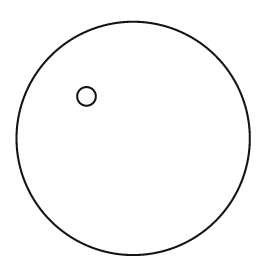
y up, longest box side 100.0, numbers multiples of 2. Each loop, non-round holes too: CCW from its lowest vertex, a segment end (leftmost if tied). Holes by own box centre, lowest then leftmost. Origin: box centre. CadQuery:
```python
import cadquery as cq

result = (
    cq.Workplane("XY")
    .moveTo(0.0, 0.0)
    .circle(50.0)
    .moveTo(-20.0, 18.0)
    .circle(4.0)
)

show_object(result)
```